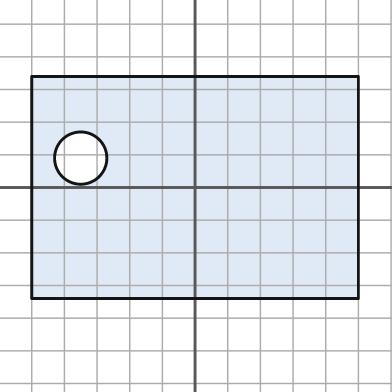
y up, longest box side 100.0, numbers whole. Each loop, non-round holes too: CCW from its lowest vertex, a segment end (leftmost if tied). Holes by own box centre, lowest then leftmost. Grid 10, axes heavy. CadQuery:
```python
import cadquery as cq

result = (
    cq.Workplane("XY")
    .moveTo(-50.0, -34.0)
    .lineTo(50.0, -34.0)
    .lineTo(50.0, 34.0)
    .lineTo(-50.0, 34.0)
    .close()
    .moveTo(-35.0, 9.0)
    .circle(8.0)
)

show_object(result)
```